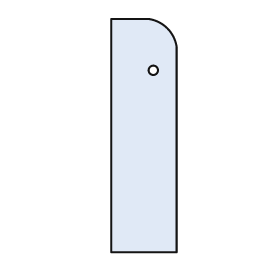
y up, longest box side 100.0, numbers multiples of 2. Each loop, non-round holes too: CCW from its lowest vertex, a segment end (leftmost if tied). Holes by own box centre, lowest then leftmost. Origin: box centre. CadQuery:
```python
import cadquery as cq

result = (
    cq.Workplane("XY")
    .moveTo(-14.0, -50.0)
    .lineTo(14.0, -50.0)
    .lineTo(14.0, 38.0)
    .threePointArc((10.0, 46.0), (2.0, 50.0))
    .lineTo(-14.0, 50.0)
    .close()
    .moveTo(4.0, 28.0)
    .circle(2.0)
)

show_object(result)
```